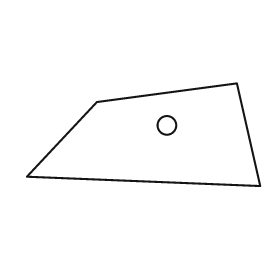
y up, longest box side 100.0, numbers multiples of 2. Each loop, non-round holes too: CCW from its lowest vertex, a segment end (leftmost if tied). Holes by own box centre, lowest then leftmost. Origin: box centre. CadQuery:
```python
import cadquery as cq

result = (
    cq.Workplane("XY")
    .moveTo(50.0, -22.0)
    .lineTo(40.0, 22.0)
    .lineTo(-20.0, 14.0)
    .lineTo(-50.0, -18.0)
    .close()
    .moveTo(10.0, 4.0)
    .circle(4.0)
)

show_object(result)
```